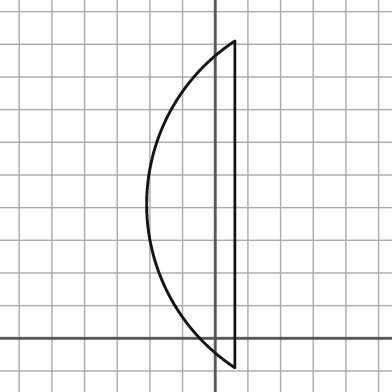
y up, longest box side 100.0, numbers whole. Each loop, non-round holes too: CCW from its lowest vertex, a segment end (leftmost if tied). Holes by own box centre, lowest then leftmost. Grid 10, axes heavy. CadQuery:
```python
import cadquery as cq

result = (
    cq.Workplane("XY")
    .moveTo(6.0, -9.0)
    .lineTo(6.0, 91.0)
    .threePointArc((-21.0, 41.0), (6.0, -9.0))
    .close()
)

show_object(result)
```